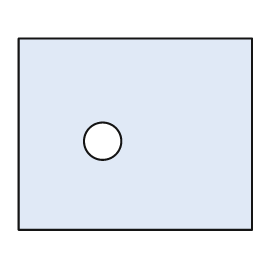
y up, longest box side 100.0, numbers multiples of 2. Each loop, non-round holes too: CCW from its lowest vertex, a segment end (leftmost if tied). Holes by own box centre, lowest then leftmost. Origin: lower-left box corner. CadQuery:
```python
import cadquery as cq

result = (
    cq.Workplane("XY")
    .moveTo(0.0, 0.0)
    .lineTo(100.0, 0.0)
    .lineTo(100.0, 82.0)
    .lineTo(0.0, 82.0)
    .close()
    .moveTo(36.0, 38.0)
    .circle(8.0)
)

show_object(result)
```